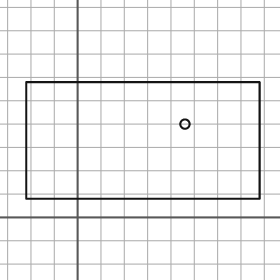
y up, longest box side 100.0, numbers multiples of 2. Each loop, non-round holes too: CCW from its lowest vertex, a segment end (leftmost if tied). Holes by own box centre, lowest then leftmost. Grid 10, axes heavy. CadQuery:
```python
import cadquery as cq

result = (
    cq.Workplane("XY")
    .moveTo(-22.0, 8.0)
    .lineTo(78.0, 8.0)
    .lineTo(78.0, 58.0)
    .lineTo(-22.0, 58.0)
    .close()
    .moveTo(46.0, 40.0)
    .circle(2.0)
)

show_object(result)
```